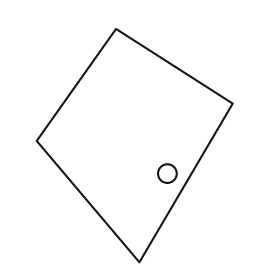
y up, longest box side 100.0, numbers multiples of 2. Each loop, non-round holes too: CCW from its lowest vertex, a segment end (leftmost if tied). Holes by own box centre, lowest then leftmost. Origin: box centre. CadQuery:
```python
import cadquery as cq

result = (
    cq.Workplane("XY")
    .moveTo(2.0, -50.0)
    .lineTo(42.0, 18.0)
    .lineTo(-8.0, 50.0)
    .lineTo(-42.0, 2.0)
    .close()
    .moveTo(14.0, -12.0)
    .circle(4.0)
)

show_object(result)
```